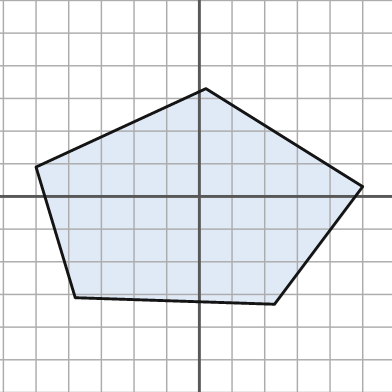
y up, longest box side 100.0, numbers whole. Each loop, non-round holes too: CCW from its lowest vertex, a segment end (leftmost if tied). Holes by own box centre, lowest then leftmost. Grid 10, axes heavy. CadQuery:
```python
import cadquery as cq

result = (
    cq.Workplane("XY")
    .moveTo(23.0, -33.0)
    .lineTo(50.0, 3.0)
    .lineTo(2.0, 33.0)
    .lineTo(-50.0, 9.0)
    .lineTo(-38.0, -31.0)
    .close()
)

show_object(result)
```